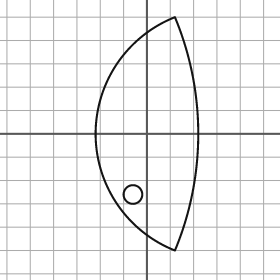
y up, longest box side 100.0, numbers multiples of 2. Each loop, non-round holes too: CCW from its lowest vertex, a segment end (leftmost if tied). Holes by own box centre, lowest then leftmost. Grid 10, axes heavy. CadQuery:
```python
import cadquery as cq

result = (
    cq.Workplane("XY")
    .moveTo(12.0, -50.0)
    .threePointArc((22.0, 0.0), (12.0, 50.0))
    .threePointArc((-22.0, 0.0), (12.0, -50.0))
    .close()
    .moveTo(-6.0, -26.0)
    .circle(4.0)
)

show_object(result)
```